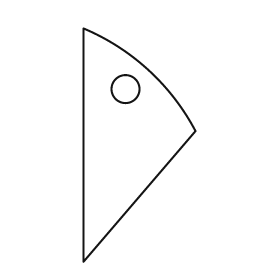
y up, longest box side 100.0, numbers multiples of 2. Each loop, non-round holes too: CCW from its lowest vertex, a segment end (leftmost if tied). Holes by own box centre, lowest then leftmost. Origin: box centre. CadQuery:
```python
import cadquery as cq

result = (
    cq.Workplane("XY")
    .moveTo(-24.0, -50.0)
    .lineTo(24.0, 6.0)
    .threePointArc((4.0, 32.0), (-24.0, 50.0))
    .close()
    .moveTo(-6.0, 24.0)
    .circle(6.0)
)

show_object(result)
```